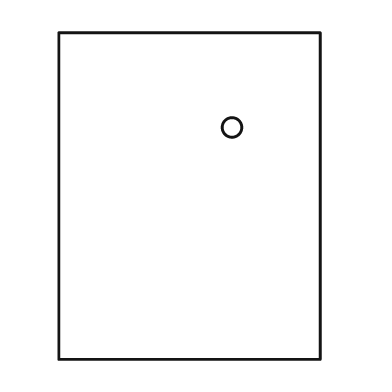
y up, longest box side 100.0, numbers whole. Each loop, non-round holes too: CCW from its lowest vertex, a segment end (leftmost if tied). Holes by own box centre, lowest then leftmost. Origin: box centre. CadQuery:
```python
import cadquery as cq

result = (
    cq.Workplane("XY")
    .moveTo(-40.0, -50.0)
    .lineTo(40.0, -50.0)
    .lineTo(40.0, 50.0)
    .lineTo(-40.0, 50.0)
    .close()
    .moveTo(13.0, 21.0)
    .circle(3.0)
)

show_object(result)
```